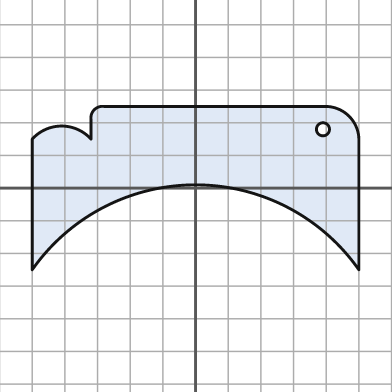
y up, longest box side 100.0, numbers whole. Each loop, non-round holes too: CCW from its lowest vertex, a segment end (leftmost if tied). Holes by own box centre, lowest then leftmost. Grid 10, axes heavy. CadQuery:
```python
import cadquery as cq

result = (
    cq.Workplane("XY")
    .moveTo(-50.0, -25.0)
    .threePointArc((0.0, 1.0), (50.0, -25.0))
    .lineTo(50.0, 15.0)
    .threePointArc((47.0, 22.0), (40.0, 25.0))
    .lineTo(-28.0, 25.0)
    .threePointArc((-31.0, 24.0), (-32.0, 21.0))
    .lineTo(-32.0, 15.0)
    .threePointArc((-41.0, 19.0), (-50.0, 15.0))
    .close()
    .moveTo(39.0, 18.0)
    .circle(2.0)
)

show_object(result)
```